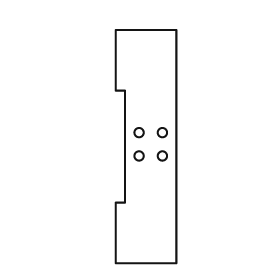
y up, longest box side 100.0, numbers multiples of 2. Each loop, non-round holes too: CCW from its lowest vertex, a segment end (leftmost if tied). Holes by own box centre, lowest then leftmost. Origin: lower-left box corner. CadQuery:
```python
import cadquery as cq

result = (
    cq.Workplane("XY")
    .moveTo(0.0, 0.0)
    .lineTo(26.0, 0.0)
    .lineTo(26.0, 100.0)
    .lineTo(0.0, 100.0)
    .lineTo(0.0, 74.0)
    .lineTo(4.0, 74.0)
    .lineTo(4.0, 26.0)
    .lineTo(0.0, 26.0)
    .close()
    .moveTo(10.0, 46.0)
    .circle(2.0)
    .moveTo(20.0, 46.0)
    .circle(2.0)
    .moveTo(10.0, 56.0)
    .circle(2.0)
    .moveTo(20.0, 56.0)
    .circle(2.0)
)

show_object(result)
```